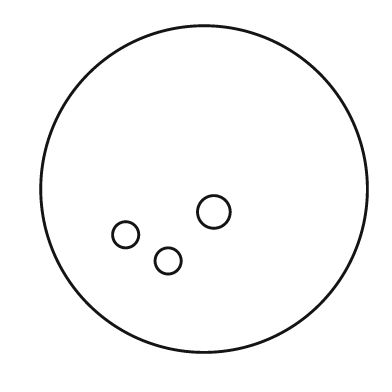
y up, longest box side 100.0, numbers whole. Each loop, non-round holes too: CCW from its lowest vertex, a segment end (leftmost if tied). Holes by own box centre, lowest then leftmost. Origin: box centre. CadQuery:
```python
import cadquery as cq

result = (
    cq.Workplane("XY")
    .moveTo(0.0, 0.0)
    .circle(50.0)
    .moveTo(-11.0, -22.0)
    .circle(4.0)
    .moveTo(-24.0, -14.0)
    .circle(4.0)
    .moveTo(3.0, -7.0)
    .circle(5.0)
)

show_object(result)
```